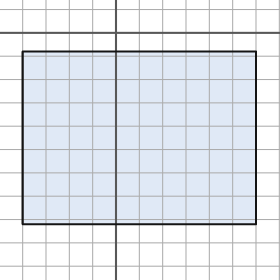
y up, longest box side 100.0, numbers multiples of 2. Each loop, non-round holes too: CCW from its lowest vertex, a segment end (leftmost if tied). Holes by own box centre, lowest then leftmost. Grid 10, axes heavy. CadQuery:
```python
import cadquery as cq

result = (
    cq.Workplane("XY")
    .moveTo(-40.0, -82.0)
    .lineTo(60.0, -82.0)
    .lineTo(60.0, -8.0)
    .lineTo(-40.0, -8.0)
    .close()
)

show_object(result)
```